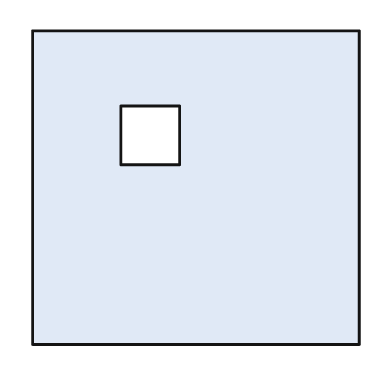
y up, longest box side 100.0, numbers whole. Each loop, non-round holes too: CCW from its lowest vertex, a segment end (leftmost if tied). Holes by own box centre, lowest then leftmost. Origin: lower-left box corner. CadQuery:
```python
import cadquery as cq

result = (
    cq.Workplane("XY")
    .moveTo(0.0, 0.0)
    .lineTo(100.0, 0.0)
    .lineTo(100.0, 96.0)
    .lineTo(0.0, 96.0)
    .close()
    .moveTo(27.0, 55.0)
    .lineTo(45.0, 55.0)
    .lineTo(45.0, 73.0)
    .lineTo(27.0, 73.0)
    .close()
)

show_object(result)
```